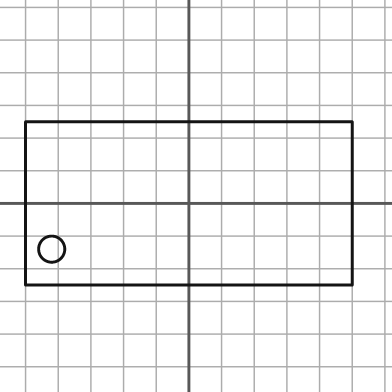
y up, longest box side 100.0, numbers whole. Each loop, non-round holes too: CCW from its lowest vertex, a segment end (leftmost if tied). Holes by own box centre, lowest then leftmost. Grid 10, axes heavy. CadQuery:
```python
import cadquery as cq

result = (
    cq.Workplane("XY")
    .moveTo(-50.0, -25.0)
    .lineTo(50.0, -25.0)
    .lineTo(50.0, 25.0)
    .lineTo(-50.0, 25.0)
    .close()
    .moveTo(-42.0, -14.0)
    .circle(4.0)
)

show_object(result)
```